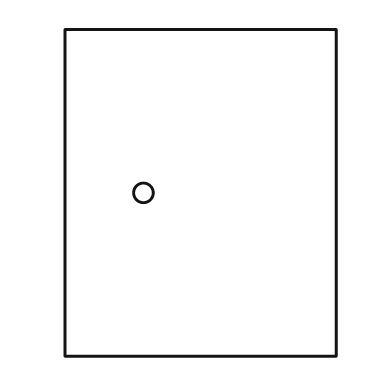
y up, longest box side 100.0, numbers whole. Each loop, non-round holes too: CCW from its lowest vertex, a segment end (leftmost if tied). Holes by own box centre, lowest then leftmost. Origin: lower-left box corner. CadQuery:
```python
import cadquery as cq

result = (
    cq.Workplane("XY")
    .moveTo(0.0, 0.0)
    .lineTo(83.0, 0.0)
    .lineTo(83.0, 100.0)
    .lineTo(0.0, 100.0)
    .close()
    .moveTo(24.0, 50.0)
    .circle(3.0)
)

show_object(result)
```